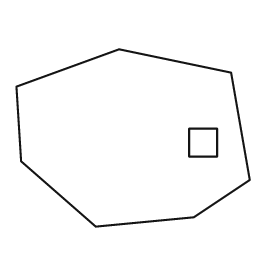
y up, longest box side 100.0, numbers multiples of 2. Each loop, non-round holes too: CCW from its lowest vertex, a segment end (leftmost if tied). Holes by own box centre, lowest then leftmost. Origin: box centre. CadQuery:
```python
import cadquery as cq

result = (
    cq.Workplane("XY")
    .moveTo(-16.0, -38.0)
    .lineTo(26.0, -34.0)
    .lineTo(50.0, -18.0)
    .lineTo(42.0, 28.0)
    .lineTo(-6.0, 38.0)
    .lineTo(-50.0, 22.0)
    .lineTo(-48.0, -10.0)
    .close()
    .moveTo(24.0, -8.0)
    .lineTo(36.0, -8.0)
    .lineTo(36.0, 4.0)
    .lineTo(24.0, 4.0)
    .close()
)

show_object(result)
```